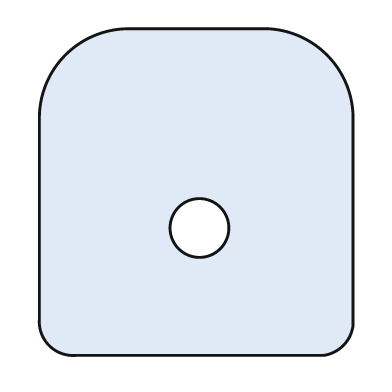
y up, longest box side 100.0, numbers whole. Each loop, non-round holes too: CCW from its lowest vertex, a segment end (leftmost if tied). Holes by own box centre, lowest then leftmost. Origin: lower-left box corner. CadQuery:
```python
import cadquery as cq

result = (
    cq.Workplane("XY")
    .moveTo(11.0, 0.0)
    .lineTo(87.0, 0.0)
    .threePointArc((93.0, 3.0), (96.0, 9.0))
    .lineTo(96.0, 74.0)
    .threePointArc((88.0, 92.0), (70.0, 100.0))
    .lineTo(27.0, 100.0)
    .threePointArc((8.0, 92.0), (0.0, 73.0))
    .lineTo(0.0, 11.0)
    .threePointArc((3.0, 3.0), (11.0, 0.0))
    .close()
    .moveTo(49.0, 39.0)
    .circle(9.0)
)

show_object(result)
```